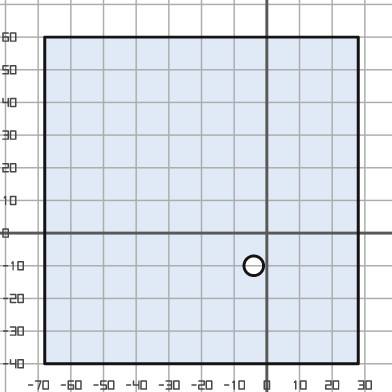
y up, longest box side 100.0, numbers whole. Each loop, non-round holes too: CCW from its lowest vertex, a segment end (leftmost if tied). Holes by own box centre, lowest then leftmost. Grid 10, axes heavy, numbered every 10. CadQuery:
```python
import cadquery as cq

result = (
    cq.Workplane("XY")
    .moveTo(-68.0, -40.0)
    .lineTo(28.0, -40.0)
    .lineTo(28.0, 60.0)
    .lineTo(-68.0, 60.0)
    .close()
    .moveTo(-4.0, -10.0)
    .circle(3.0)
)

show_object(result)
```